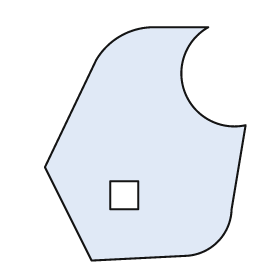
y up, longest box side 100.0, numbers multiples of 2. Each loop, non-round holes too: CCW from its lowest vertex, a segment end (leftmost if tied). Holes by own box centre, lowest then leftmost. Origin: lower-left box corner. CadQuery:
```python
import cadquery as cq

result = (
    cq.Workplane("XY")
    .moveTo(20.0, 0.0)
    .lineTo(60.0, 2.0)
    .threePointArc((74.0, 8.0), (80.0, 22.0))
    .lineTo(86.0, 58.0)
    .threePointArc((60.0, 72.0), (70.0, 100.0))
    .lineTo(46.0, 100.0)
    .threePointArc((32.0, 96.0), (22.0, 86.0))
    .lineTo(0.0, 40.0)
    .close()
    .moveTo(28.0, 22.0)
    .lineTo(40.0, 22.0)
    .lineTo(40.0, 34.0)
    .lineTo(28.0, 34.0)
    .close()
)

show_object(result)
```